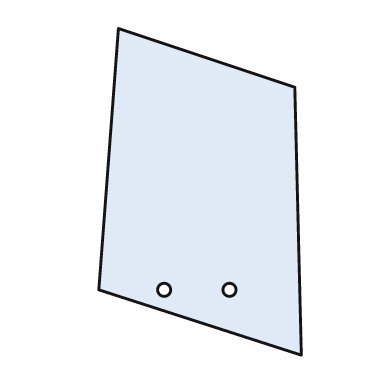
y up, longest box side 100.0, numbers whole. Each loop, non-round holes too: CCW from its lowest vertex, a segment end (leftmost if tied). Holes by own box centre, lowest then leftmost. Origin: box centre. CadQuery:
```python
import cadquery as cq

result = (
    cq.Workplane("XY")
    .moveTo(31.0, -50.0)
    .lineTo(29.0, 32.0)
    .lineTo(-25.0, 50.0)
    .lineTo(-31.0, -30.0)
    .close()
    .moveTo(-11.0, -30.0)
    .circle(2.0)
    .moveTo(9.0, -30.0)
    .circle(2.0)
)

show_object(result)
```